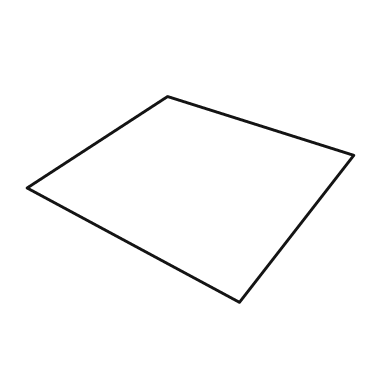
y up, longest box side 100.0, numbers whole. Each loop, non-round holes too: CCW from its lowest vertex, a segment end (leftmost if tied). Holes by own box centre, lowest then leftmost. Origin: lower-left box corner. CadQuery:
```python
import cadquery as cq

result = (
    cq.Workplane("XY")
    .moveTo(65.0, 0.0)
    .lineTo(100.0, 45.0)
    .lineTo(43.0, 63.0)
    .lineTo(0.0, 35.0)
    .close()
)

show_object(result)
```